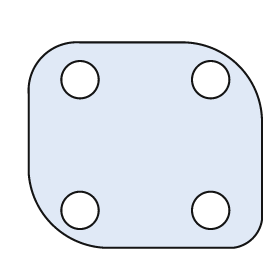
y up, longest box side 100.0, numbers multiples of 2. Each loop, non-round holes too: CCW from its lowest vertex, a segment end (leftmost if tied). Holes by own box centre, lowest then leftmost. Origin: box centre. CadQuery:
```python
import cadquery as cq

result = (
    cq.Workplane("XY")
    .moveTo(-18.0, -44.0)
    .lineTo(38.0, -44.0)
    .threePointArc((46.0, -40.0), (50.0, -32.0))
    .lineTo(50.0, 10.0)
    .threePointArc((40.0, 34.0), (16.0, 44.0))
    .lineTo(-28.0, 44.0)
    .threePointArc((-44.0, 38.0), (-50.0, 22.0))
    .lineTo(-50.0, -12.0)
    .threePointArc((-40.0, -34.0), (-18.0, -44.0))
    .close()
    .moveTo(-28.0, -28.0)
    .circle(8.0)
    .moveTo(28.0, -28.0)
    .circle(8.0)
    .moveTo(-28.0, 28.0)
    .circle(8.0)
    .moveTo(28.0, 28.0)
    .circle(8.0)
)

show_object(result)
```